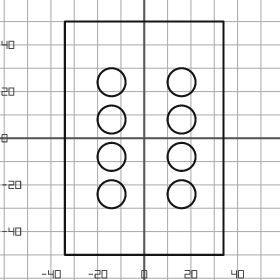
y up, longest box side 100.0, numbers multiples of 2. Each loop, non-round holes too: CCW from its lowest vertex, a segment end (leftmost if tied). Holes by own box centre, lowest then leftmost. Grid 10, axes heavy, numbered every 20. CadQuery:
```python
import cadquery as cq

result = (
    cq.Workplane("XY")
    .moveTo(-34.0, -50.0)
    .lineTo(34.0, -50.0)
    .lineTo(34.0, 50.0)
    .lineTo(-34.0, 50.0)
    .close()
    .moveTo(-14.0, -24.0)
    .circle(6.0)
    .moveTo(16.0, -24.0)
    .circle(6.0)
    .moveTo(-14.0, -8.0)
    .circle(6.0)
    .moveTo(16.0, -8.0)
    .circle(6.0)
    .moveTo(-14.0, 8.0)
    .circle(6.0)
    .moveTo(16.0, 8.0)
    .circle(6.0)
    .moveTo(-14.0, 24.0)
    .circle(6.0)
    .moveTo(16.0, 24.0)
    .circle(6.0)
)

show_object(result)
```